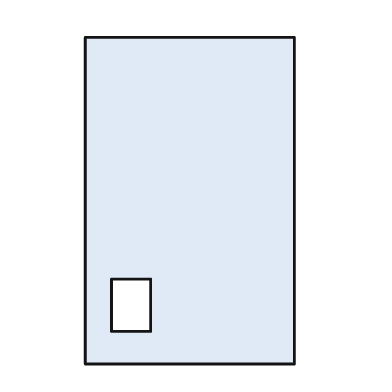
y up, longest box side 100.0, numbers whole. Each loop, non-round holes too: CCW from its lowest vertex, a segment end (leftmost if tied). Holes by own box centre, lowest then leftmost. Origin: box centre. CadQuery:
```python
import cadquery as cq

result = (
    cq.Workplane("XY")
    .moveTo(-32.0, -50.0)
    .lineTo(32.0, -50.0)
    .lineTo(32.0, 50.0)
    .lineTo(-32.0, 50.0)
    .close()
    .moveTo(-24.0, -40.0)
    .lineTo(-12.0, -40.0)
    .lineTo(-12.0, -24.0)
    .lineTo(-24.0, -24.0)
    .close()
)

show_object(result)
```